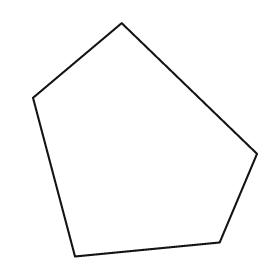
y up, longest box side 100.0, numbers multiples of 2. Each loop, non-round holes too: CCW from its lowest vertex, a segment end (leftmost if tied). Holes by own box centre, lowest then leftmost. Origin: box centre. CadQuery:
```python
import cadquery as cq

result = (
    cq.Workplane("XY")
    .moveTo(-30.0, -50.0)
    .lineTo(32.0, -44.0)
    .lineTo(48.0, -6.0)
    .lineTo(-10.0, 50.0)
    .lineTo(-48.0, 18.0)
    .close()
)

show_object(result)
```